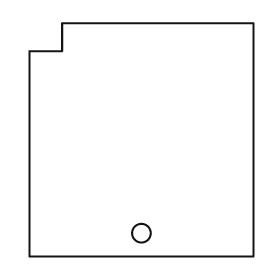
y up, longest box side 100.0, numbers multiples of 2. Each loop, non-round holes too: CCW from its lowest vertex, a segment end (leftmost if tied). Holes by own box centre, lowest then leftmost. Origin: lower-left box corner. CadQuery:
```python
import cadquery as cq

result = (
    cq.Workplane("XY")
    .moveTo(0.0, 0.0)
    .lineTo(96.0, 0.0)
    .lineTo(96.0, 100.0)
    .lineTo(14.0, 100.0)
    .lineTo(14.0, 88.0)
    .lineTo(0.0, 88.0)
    .close()
    .moveTo(48.0, 10.0)
    .circle(4.0)
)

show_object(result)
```